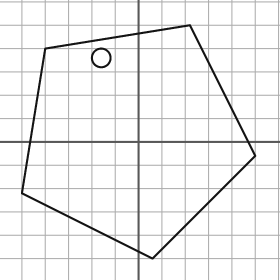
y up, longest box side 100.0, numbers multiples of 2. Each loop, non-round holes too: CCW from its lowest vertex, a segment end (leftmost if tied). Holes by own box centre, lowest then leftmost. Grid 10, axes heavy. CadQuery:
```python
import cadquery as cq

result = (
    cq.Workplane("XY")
    .moveTo(6.0, -50.0)
    .lineTo(50.0, -6.0)
    .lineTo(22.0, 50.0)
    .lineTo(-40.0, 40.0)
    .lineTo(-50.0, -22.0)
    .close()
    .moveTo(-16.0, 36.0)
    .circle(4.0)
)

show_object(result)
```